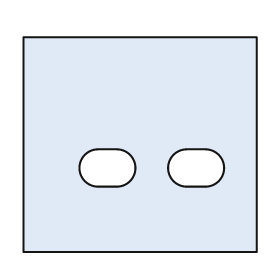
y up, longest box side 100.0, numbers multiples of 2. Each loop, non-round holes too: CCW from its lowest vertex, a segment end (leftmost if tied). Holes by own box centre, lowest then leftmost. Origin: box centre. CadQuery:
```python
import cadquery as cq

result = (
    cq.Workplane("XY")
    .moveTo(-50.0, -46.0)
    .lineTo(50.0, -46.0)
    .lineTo(50.0, 46.0)
    .lineTo(-50.0, 46.0)
    .close()
    .moveTo(-18.0, -18.0)
    .lineTo(-10.0, -18.0)
    .threePointArc((-2.0, -10.0), (-10.0, -2.0))
    .lineTo(-18.0, -2.0)
    .threePointArc((-26.0, -10.0), (-18.0, -18.0))
    .close()
    .moveTo(20.0, -18.0)
    .lineTo(28.0, -18.0)
    .threePointArc((36.0, -10.0), (28.0, -2.0))
    .lineTo(20.0, -2.0)
    .threePointArc((12.0, -10.0), (20.0, -18.0))
    .close()
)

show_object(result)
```